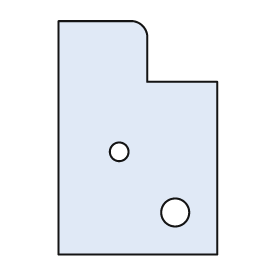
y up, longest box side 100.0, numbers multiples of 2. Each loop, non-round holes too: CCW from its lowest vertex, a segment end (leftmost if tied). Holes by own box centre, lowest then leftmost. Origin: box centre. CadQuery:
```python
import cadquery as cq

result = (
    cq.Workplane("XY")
    .moveTo(-34.0, -50.0)
    .lineTo(34.0, -50.0)
    .lineTo(34.0, 24.0)
    .lineTo(4.0, 24.0)
    .lineTo(4.0, 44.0)
    .threePointArc((2.0, 48.0), (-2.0, 50.0))
    .lineTo(-34.0, 50.0)
    .close()
    .moveTo(16.0, -32.0)
    .circle(6.0)
    .moveTo(-8.0, -6.0)
    .circle(4.0)
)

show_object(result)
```